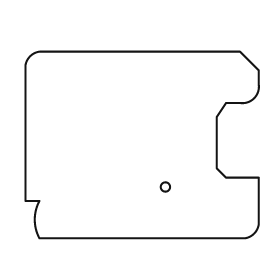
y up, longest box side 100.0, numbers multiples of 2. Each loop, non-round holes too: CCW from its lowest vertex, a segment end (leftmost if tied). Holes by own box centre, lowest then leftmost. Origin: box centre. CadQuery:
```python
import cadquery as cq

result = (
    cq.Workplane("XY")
    .moveTo(-44.0, -40.0)
    .lineTo(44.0, -40.0)
    .threePointArc((48.0, -38.0), (50.0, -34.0))
    .lineTo(50.0, -14.0)
    .lineTo(36.0, -14.0)
    .lineTo(32.0, -10.0)
    .lineTo(32.0, 12.0)
    .lineTo(36.0, 18.0)
    .lineTo(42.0, 18.0)
    .threePointArc((48.0, 20.0), (50.0, 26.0))
    .lineTo(50.0, 32.0)
    .lineTo(42.0, 40.0)
    .lineTo(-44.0, 40.0)
    .threePointArc((-48.0, 38.0), (-50.0, 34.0))
    .lineTo(-50.0, -24.0)
    .lineTo(-44.0, -24.0)
    .threePointArc((-46.0, -32.0), (-44.0, -40.0))
    .close()
    .moveTo(10.0, -18.0)
    .circle(2.0)
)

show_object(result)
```